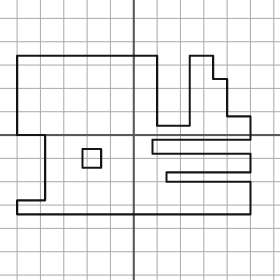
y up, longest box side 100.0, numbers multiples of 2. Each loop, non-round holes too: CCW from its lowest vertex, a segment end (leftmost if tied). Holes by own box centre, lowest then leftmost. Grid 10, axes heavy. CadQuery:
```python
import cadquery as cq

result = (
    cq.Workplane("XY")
    .moveTo(-50.0, -34.0)
    .lineTo(50.0, -34.0)
    .lineTo(50.0, -20.0)
    .lineTo(14.0, -20.0)
    .lineTo(14.0, -16.0)
    .lineTo(50.0, -16.0)
    .lineTo(50.0, -8.0)
    .lineTo(8.0, -8.0)
    .lineTo(8.0, -2.0)
    .lineTo(50.0, -2.0)
    .lineTo(50.0, 8.0)
    .lineTo(40.0, 8.0)
    .lineTo(40.0, 24.0)
    .lineTo(34.0, 24.0)
    .lineTo(34.0, 34.0)
    .lineTo(24.0, 34.0)
    .lineTo(24.0, 4.0)
    .lineTo(10.0, 4.0)
    .lineTo(10.0, 34.0)
    .lineTo(-50.0, 34.0)
    .lineTo(-50.0, 0.0)
    .lineTo(-38.0, 0.0)
    .lineTo(-38.0, -28.0)
    .lineTo(-50.0, -28.0)
    .close()
    .moveTo(-22.0, -14.0)
    .lineTo(-14.0, -14.0)
    .lineTo(-14.0, -6.0)
    .lineTo(-22.0, -6.0)
    .close()
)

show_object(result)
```